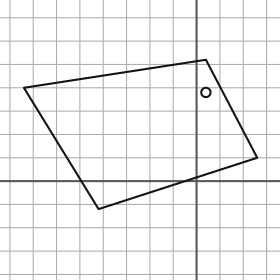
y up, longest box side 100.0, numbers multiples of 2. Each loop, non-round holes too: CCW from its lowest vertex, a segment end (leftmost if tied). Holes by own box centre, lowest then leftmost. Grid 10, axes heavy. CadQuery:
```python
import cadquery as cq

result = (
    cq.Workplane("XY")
    .moveTo(-42.0, -12.0)
    .lineTo(26.0, 10.0)
    .lineTo(4.0, 52.0)
    .lineTo(-74.0, 40.0)
    .close()
    .moveTo(4.0, 38.0)
    .circle(2.0)
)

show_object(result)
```